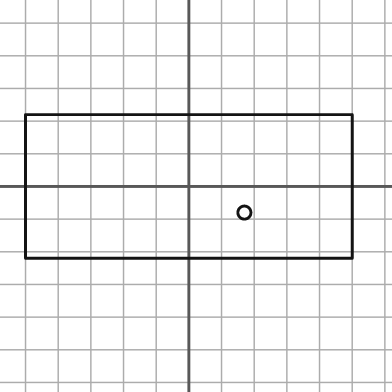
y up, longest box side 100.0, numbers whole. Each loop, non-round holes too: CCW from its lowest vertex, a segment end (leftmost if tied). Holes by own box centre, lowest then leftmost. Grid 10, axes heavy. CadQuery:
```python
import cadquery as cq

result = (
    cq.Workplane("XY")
    .moveTo(-50.0, -22.0)
    .lineTo(50.0, -22.0)
    .lineTo(50.0, 22.0)
    .lineTo(-50.0, 22.0)
    .close()
    .moveTo(17.0, -8.0)
    .circle(2.0)
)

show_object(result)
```